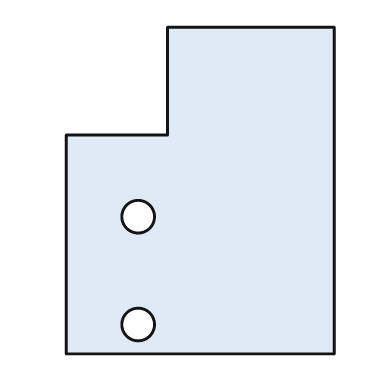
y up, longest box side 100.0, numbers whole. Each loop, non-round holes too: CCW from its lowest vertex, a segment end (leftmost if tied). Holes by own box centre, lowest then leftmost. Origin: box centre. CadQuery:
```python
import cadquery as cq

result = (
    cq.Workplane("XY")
    .moveTo(-41.0, -50.0)
    .lineTo(41.0, -50.0)
    .lineTo(41.0, 50.0)
    .lineTo(-10.0, 50.0)
    .lineTo(-10.0, 17.0)
    .lineTo(-41.0, 17.0)
    .close()
    .moveTo(-19.0, -41.0)
    .circle(5.0)
    .moveTo(-19.0, -8.0)
    .circle(5.0)
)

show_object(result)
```